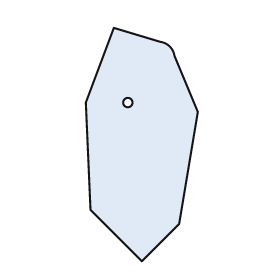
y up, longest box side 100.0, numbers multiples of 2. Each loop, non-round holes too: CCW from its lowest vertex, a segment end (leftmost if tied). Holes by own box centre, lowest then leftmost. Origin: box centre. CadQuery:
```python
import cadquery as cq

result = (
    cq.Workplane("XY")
    .moveTo(0.0, -50.0)
    .lineTo(16.0, -34.0)
    .lineTo(24.0, 14.0)
    .lineTo(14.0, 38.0)
    .threePointArc((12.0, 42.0), (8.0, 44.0))
    .lineTo(-12.0, 50.0)
    .lineTo(-24.0, 18.0)
    .lineTo(-22.0, -28.0)
    .close()
    .moveTo(-6.0, 18.0)
    .circle(2.0)
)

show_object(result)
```